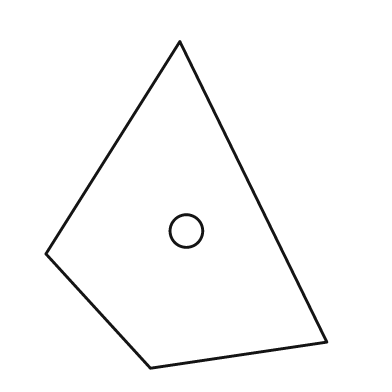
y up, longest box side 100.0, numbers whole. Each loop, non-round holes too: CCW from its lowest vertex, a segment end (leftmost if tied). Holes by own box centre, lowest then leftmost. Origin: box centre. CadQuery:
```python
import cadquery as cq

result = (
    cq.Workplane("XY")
    .moveTo(-11.0, -50.0)
    .lineTo(43.0, -42.0)
    .lineTo(-2.0, 50.0)
    .lineTo(-43.0, -15.0)
    .close()
    .moveTo(0.0, -8.0)
    .circle(5.0)
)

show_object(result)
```